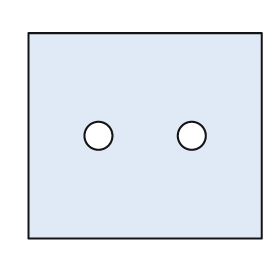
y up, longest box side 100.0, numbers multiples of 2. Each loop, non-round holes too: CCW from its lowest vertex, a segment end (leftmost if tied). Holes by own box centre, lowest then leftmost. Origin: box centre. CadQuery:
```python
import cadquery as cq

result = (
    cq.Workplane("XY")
    .moveTo(-50.0, -44.0)
    .lineTo(50.0, -44.0)
    .lineTo(50.0, 44.0)
    .lineTo(-50.0, 44.0)
    .close()
    .moveTo(-20.0, 0.0)
    .circle(6.0)
    .moveTo(20.0, 0.0)
    .circle(6.0)
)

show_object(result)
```